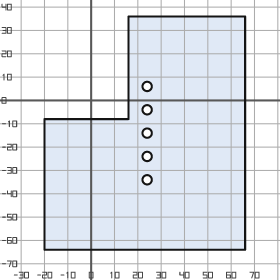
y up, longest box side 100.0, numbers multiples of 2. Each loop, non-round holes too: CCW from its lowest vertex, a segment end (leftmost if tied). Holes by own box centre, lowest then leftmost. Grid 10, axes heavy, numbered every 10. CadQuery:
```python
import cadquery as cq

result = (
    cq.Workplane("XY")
    .moveTo(-20.0, -64.0)
    .lineTo(66.0, -64.0)
    .lineTo(66.0, 36.0)
    .lineTo(16.0, 36.0)
    .lineTo(16.0, -8.0)
    .lineTo(-20.0, -8.0)
    .close()
    .moveTo(24.0, -34.0)
    .circle(2.0)
    .moveTo(24.0, -24.0)
    .circle(2.0)
    .moveTo(24.0, -14.0)
    .circle(2.0)
    .moveTo(24.0, -4.0)
    .circle(2.0)
    .moveTo(24.0, 6.0)
    .circle(2.0)
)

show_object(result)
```